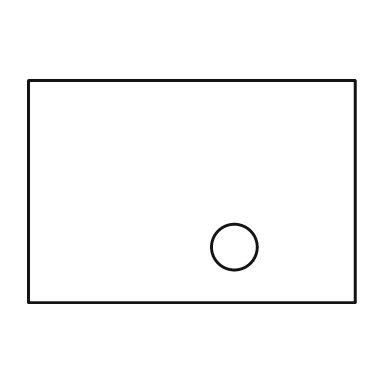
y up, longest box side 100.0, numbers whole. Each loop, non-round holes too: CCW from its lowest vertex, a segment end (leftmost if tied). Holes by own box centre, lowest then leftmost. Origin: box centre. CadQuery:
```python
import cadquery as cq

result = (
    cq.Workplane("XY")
    .moveTo(-50.0, -34.0)
    .lineTo(50.0, -34.0)
    .lineTo(50.0, 34.0)
    .lineTo(-50.0, 34.0)
    .close()
    .moveTo(13.0, -17.0)
    .circle(7.0)
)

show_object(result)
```